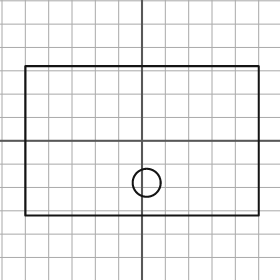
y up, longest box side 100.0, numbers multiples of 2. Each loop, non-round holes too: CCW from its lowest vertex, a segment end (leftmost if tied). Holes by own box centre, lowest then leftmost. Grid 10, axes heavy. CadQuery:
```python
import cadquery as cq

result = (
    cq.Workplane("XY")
    .moveTo(-50.0, -32.0)
    .lineTo(50.0, -32.0)
    .lineTo(50.0, 32.0)
    .lineTo(-50.0, 32.0)
    .close()
    .moveTo(2.0, -18.0)
    .circle(6.0)
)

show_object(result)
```